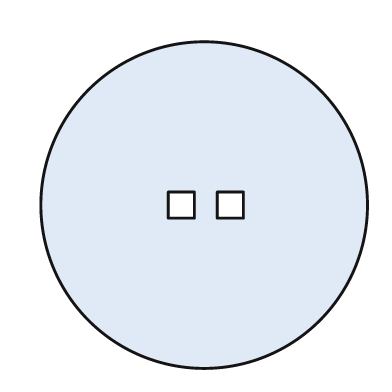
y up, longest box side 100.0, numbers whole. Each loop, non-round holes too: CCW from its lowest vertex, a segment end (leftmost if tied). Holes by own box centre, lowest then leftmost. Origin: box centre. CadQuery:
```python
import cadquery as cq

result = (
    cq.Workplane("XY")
    .moveTo(0.0, 0.0)
    .circle(50.0)
    .moveTo(-11.0, -4.0)
    .lineTo(-3.0, -4.0)
    .lineTo(-3.0, 4.0)
    .lineTo(-11.0, 4.0)
    .close()
    .moveTo(4.0, -4.0)
    .lineTo(12.0, -4.0)
    .lineTo(12.0, 4.0)
    .lineTo(4.0, 4.0)
    .close()
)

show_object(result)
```